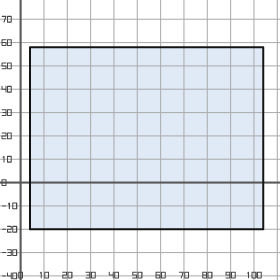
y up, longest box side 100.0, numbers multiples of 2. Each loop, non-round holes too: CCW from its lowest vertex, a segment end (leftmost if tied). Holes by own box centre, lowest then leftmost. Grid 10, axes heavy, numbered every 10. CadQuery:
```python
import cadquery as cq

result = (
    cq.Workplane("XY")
    .moveTo(4.0, -20.0)
    .lineTo(104.0, -20.0)
    .lineTo(104.0, 58.0)
    .lineTo(4.0, 58.0)
    .close()
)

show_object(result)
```